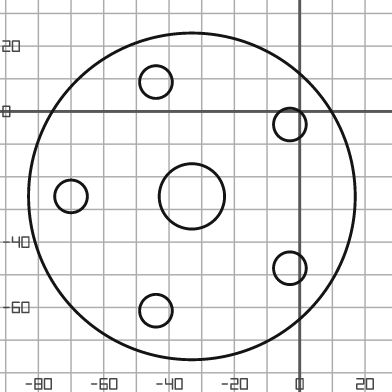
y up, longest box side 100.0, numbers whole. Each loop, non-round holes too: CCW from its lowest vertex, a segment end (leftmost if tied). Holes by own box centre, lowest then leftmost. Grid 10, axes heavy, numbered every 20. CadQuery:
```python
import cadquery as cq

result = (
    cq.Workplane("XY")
    .moveTo(-33.0, -26.0)
    .circle(50.0)
    .moveTo(-44.0, -61.0)
    .circle(5.0)
    .moveTo(-3.0, -48.0)
    .circle(5.0)
    .moveTo(-70.0, -26.0)
    .circle(5.0)
    .moveTo(-33.0, -26.0)
    .circle(10.0)
    .moveTo(-3.0, -4.0)
    .circle(5.0)
    .moveTo(-44.0, 9.0)
    .circle(5.0)
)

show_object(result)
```